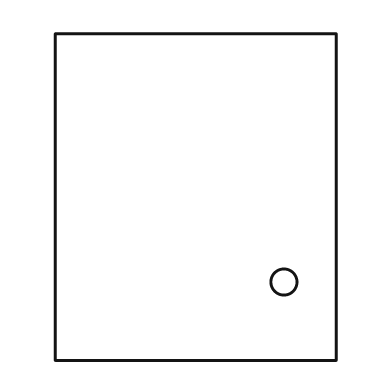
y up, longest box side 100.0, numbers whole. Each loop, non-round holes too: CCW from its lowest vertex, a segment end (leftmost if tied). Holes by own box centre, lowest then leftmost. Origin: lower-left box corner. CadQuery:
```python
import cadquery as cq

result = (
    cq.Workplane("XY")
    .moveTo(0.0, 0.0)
    .lineTo(86.0, 0.0)
    .lineTo(86.0, 100.0)
    .lineTo(0.0, 100.0)
    .close()
    .moveTo(70.0, 24.0)
    .circle(4.0)
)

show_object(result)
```